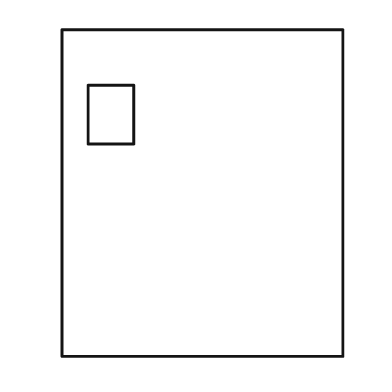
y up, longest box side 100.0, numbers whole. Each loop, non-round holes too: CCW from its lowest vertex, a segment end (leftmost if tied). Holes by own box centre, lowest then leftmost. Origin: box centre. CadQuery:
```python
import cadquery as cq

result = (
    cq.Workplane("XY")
    .moveTo(-43.0, -50.0)
    .lineTo(43.0, -50.0)
    .lineTo(43.0, 50.0)
    .lineTo(-43.0, 50.0)
    .close()
    .moveTo(-35.0, 15.0)
    .lineTo(-21.0, 15.0)
    .lineTo(-21.0, 33.0)
    .lineTo(-35.0, 33.0)
    .close()
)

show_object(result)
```